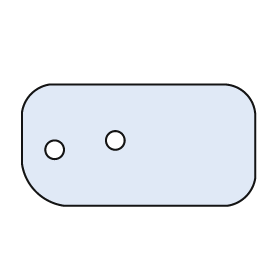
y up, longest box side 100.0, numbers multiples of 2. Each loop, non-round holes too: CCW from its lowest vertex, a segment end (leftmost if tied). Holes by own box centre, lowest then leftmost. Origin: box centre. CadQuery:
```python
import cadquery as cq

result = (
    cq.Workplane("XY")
    .moveTo(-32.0, -26.0)
    .lineTo(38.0, -26.0)
    .threePointArc((46.0, -22.0), (50.0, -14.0))
    .lineTo(50.0, 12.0)
    .threePointArc((46.0, 22.0), (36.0, 26.0))
    .lineTo(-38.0, 26.0)
    .threePointArc((-46.0, 22.0), (-50.0, 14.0))
    .lineTo(-50.0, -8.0)
    .threePointArc((-44.0, -20.0), (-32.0, -26.0))
    .close()
    .moveTo(-36.0, -2.0)
    .circle(4.0)
    .moveTo(-10.0, 2.0)
    .circle(4.0)
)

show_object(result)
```